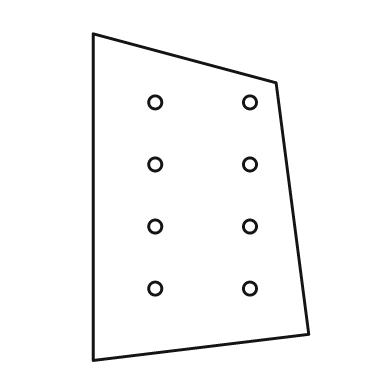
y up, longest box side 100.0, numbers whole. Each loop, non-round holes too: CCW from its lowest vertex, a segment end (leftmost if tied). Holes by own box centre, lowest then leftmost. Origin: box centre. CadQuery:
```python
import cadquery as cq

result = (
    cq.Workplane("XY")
    .moveTo(-33.0, -50.0)
    .lineTo(33.0, -42.0)
    .lineTo(23.0, 35.0)
    .lineTo(-33.0, 50.0)
    .close()
    .moveTo(-14.0, -28.0)
    .circle(2.0)
    .moveTo(15.0, -28.0)
    .circle(2.0)
    .moveTo(-14.0, -9.0)
    .circle(2.0)
    .moveTo(15.0, -9.0)
    .circle(2.0)
    .moveTo(-14.0, 10.0)
    .circle(2.0)
    .moveTo(15.0, 10.0)
    .circle(2.0)
    .moveTo(-14.0, 29.0)
    .circle(2.0)
    .moveTo(15.0, 29.0)
    .circle(2.0)
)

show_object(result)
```